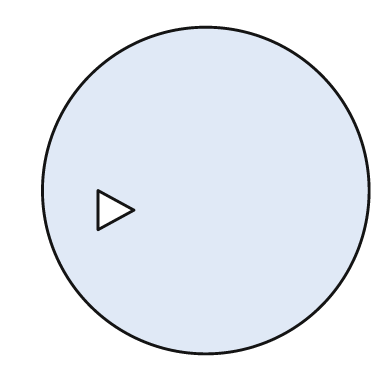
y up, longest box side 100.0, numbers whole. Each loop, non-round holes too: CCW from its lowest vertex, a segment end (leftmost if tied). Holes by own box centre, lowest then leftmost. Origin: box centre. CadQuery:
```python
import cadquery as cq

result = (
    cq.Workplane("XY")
    .moveTo(0.0, 0.0)
    .circle(50.0)
    .moveTo(-33.0, -12.0)
    .lineTo(-22.0, -6.0)
    .lineTo(-33.0, 0.0)
    .close()
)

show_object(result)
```